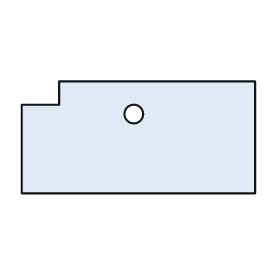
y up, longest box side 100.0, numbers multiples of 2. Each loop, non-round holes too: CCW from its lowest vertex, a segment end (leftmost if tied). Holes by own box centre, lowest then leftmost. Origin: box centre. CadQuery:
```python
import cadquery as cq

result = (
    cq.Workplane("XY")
    .moveTo(-50.0, -24.0)
    .lineTo(50.0, -24.0)
    .lineTo(50.0, 24.0)
    .lineTo(-34.0, 24.0)
    .lineTo(-34.0, 14.0)
    .lineTo(-50.0, 14.0)
    .close()
    .moveTo(-2.0, 10.0)
    .circle(4.0)
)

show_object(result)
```